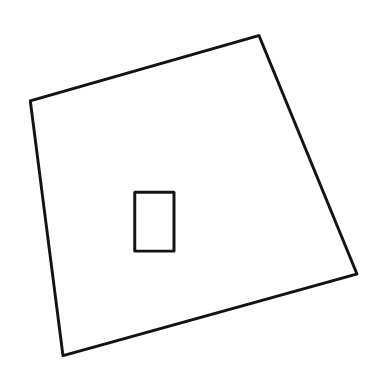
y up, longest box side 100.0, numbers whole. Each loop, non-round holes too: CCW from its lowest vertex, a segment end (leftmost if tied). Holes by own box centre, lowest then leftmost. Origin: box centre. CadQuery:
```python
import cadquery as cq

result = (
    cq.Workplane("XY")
    .moveTo(-40.0, -49.0)
    .lineTo(50.0, -24.0)
    .lineTo(20.0, 49.0)
    .lineTo(-50.0, 29.0)
    .close()
    .moveTo(-18.0, -17.0)
    .lineTo(-6.0, -17.0)
    .lineTo(-6.0, 1.0)
    .lineTo(-18.0, 1.0)
    .close()
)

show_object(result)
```